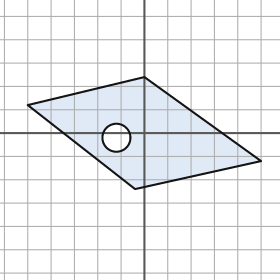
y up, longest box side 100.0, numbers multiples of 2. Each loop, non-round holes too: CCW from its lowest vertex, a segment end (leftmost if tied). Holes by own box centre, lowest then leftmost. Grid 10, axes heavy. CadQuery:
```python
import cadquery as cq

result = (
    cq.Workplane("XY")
    .moveTo(-4.0, -24.0)
    .lineTo(50.0, -12.0)
    .lineTo(0.0, 24.0)
    .lineTo(-50.0, 12.0)
    .close()
    .moveTo(-12.0, -2.0)
    .circle(6.0)
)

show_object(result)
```